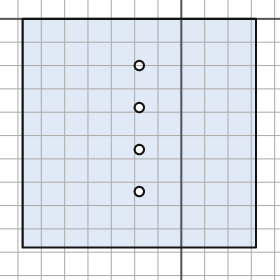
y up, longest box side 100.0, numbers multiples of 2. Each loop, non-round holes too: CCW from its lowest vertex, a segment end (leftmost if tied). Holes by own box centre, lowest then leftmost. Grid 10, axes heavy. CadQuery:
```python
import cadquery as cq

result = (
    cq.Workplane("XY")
    .moveTo(-68.0, -98.0)
    .lineTo(32.0, -98.0)
    .lineTo(32.0, 0.0)
    .lineTo(-68.0, 0.0)
    .close()
    .moveTo(-18.0, -74.0)
    .circle(2.0)
    .moveTo(-18.0, -56.0)
    .circle(2.0)
    .moveTo(-18.0, -38.0)
    .circle(2.0)
    .moveTo(-18.0, -20.0)
    .circle(2.0)
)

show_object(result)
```